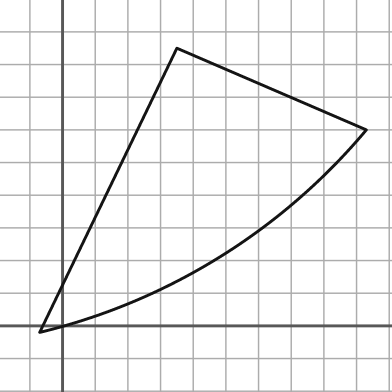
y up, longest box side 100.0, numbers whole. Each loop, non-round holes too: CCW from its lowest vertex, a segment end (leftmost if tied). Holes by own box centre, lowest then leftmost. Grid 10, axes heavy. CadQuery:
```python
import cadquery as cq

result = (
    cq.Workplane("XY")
    .moveTo(-7.0, -2.0)
    .threePointArc((48.0, 21.0), (93.0, 60.0))
    .lineTo(35.0, 85.0)
    .close()
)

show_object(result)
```